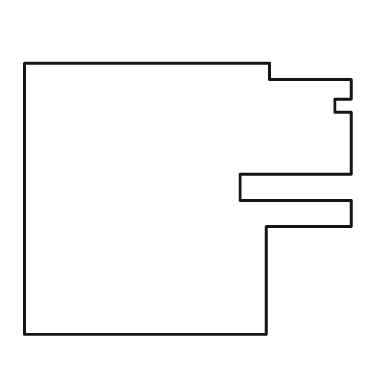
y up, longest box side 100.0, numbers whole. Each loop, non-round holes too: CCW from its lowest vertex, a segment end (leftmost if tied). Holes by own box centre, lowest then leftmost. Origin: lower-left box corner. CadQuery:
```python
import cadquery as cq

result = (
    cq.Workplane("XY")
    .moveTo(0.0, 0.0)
    .lineTo(74.0, 0.0)
    .lineTo(74.0, 33.0)
    .lineTo(100.0, 33.0)
    .lineTo(100.0, 41.0)
    .lineTo(66.0, 41.0)
    .lineTo(66.0, 49.0)
    .lineTo(100.0, 49.0)
    .lineTo(100.0, 68.0)
    .lineTo(95.0, 68.0)
    .lineTo(95.0, 72.0)
    .lineTo(100.0, 72.0)
    .lineTo(100.0, 78.0)
    .lineTo(75.0, 78.0)
    .lineTo(75.0, 83.0)
    .lineTo(0.0, 83.0)
    .close()
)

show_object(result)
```